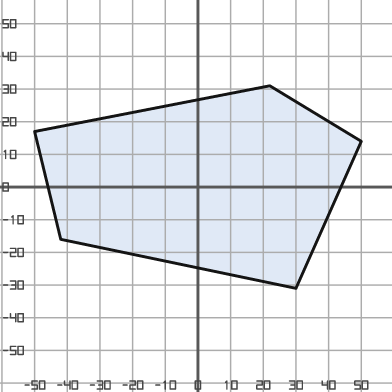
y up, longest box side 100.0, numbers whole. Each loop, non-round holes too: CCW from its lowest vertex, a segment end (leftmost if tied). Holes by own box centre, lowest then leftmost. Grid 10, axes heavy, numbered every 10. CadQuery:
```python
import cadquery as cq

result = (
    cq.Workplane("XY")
    .moveTo(30.0, -31.0)
    .lineTo(50.0, 14.0)
    .lineTo(22.0, 31.0)
    .lineTo(-50.0, 17.0)
    .lineTo(-42.0, -16.0)
    .close()
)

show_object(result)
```